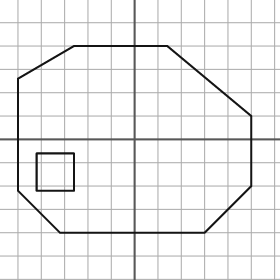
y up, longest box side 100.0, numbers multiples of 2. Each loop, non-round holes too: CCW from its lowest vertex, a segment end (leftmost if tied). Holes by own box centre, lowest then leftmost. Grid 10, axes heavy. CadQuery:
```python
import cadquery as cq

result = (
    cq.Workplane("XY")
    .moveTo(-32.0, -40.0)
    .lineTo(30.0, -40.0)
    .lineTo(50.0, -20.0)
    .lineTo(50.0, 10.0)
    .lineTo(14.0, 40.0)
    .lineTo(-26.0, 40.0)
    .lineTo(-50.0, 26.0)
    .lineTo(-50.0, -22.0)
    .close()
    .moveTo(-42.0, -22.0)
    .lineTo(-26.0, -22.0)
    .lineTo(-26.0, -6.0)
    .lineTo(-42.0, -6.0)
    .close()
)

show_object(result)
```